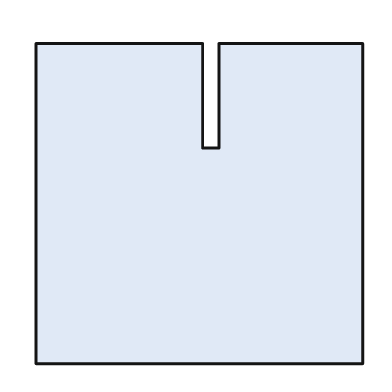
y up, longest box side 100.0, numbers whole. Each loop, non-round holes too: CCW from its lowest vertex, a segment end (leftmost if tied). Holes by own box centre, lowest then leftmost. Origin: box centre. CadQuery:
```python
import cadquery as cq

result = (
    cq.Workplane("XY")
    .moveTo(-50.0, -49.0)
    .lineTo(50.0, -49.0)
    .lineTo(50.0, 49.0)
    .lineTo(6.0, 49.0)
    .lineTo(6.0, 17.0)
    .lineTo(1.0, 17.0)
    .lineTo(1.0, 49.0)
    .lineTo(-50.0, 49.0)
    .close()
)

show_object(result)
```